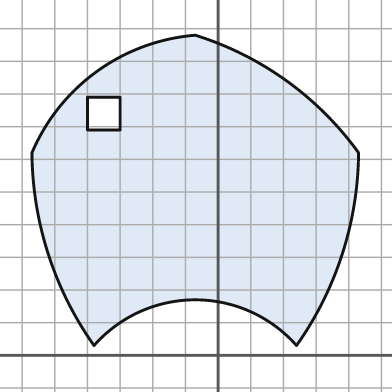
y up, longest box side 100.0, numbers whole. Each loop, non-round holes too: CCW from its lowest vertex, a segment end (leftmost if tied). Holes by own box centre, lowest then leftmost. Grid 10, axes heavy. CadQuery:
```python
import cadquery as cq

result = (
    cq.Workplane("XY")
    .moveTo(-38.0, 3.0)
    .threePointArc((-7.0, 17.0), (24.0, 3.0))
    .threePointArc((38.0, 31.0), (43.0, 62.0))
    .threePointArc((21.0, 84.0), (-7.0, 98.0))
    .threePointArc((-37.0, 87.0), (-57.0, 62.0))
    .threePointArc((-52.0, 31.0), (-38.0, 3.0))
    .close()
    .moveTo(-40.0, 69.0)
    .lineTo(-30.0, 69.0)
    .lineTo(-30.0, 79.0)
    .lineTo(-40.0, 79.0)
    .close()
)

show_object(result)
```